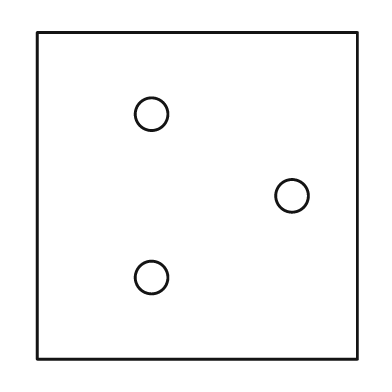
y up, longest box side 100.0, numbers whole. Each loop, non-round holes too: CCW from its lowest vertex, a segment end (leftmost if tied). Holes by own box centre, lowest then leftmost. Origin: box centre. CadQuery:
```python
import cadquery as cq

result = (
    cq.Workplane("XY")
    .moveTo(-49.0, -50.0)
    .lineTo(49.0, -50.0)
    .lineTo(49.0, 50.0)
    .lineTo(-49.0, 50.0)
    .close()
    .moveTo(-14.0, -25.0)
    .circle(5.0)
    .moveTo(29.0, 0.0)
    .circle(5.0)
    .moveTo(-14.0, 25.0)
    .circle(5.0)
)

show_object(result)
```